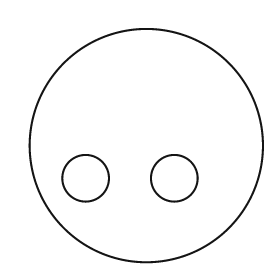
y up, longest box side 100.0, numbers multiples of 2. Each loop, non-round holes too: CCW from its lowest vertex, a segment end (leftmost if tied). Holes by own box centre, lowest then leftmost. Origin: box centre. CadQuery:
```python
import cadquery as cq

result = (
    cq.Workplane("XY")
    .moveTo(0.0, 0.0)
    .circle(50.0)
    .moveTo(-26.0, -14.0)
    .circle(10.0)
    .moveTo(12.0, -14.0)
    .circle(10.0)
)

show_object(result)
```